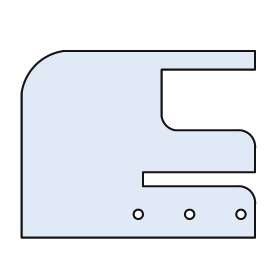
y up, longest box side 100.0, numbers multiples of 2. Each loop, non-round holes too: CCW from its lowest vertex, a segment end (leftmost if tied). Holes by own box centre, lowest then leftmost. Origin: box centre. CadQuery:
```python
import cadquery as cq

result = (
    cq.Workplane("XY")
    .moveTo(-50.0, -40.0)
    .lineTo(50.0, -40.0)
    .lineTo(50.0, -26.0)
    .threePointArc((48.0, -20.0), (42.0, -18.0))
    .lineTo(2.0, -18.0)
    .lineTo(2.0, -12.0)
    .lineTo(50.0, -12.0)
    .lineTo(50.0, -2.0)
    .threePointArc((48.0, 4.0), (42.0, 6.0))
    .lineTo(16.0, 6.0)
    .threePointArc((12.0, 8.0), (10.0, 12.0))
    .lineTo(10.0, 32.0)
    .lineTo(50.0, 32.0)
    .lineTo(50.0, 40.0)
    .lineTo(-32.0, 40.0)
    .threePointArc((-44.0, 34.0), (-50.0, 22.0))
    .close()
    .moveTo(0.0, -30.0)
    .circle(2.0)
    .moveTo(22.0, -30.0)
    .circle(2.0)
    .moveTo(44.0, -30.0)
    .circle(2.0)
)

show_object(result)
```